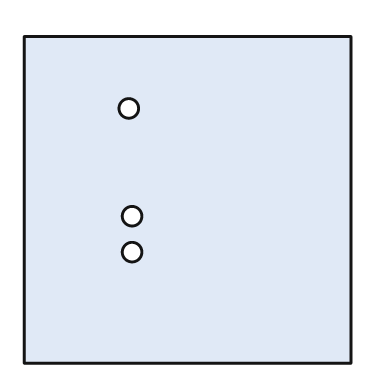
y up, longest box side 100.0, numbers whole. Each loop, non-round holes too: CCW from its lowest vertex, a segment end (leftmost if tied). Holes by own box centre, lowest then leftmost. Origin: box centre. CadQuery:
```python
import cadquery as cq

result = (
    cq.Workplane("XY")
    .moveTo(-50.0, -50.0)
    .lineTo(50.0, -50.0)
    .lineTo(50.0, 50.0)
    .lineTo(-50.0, 50.0)
    .close()
    .moveTo(-17.0, -16.0)
    .circle(3.0)
    .moveTo(-17.0, -5.0)
    .circle(3.0)
    .moveTo(-18.0, 28.0)
    .circle(3.0)
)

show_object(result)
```